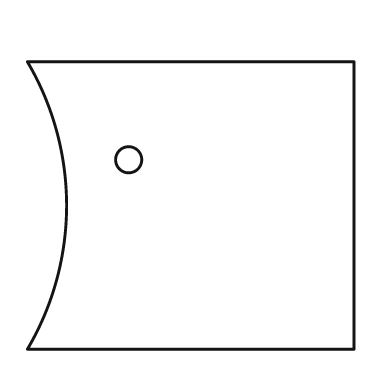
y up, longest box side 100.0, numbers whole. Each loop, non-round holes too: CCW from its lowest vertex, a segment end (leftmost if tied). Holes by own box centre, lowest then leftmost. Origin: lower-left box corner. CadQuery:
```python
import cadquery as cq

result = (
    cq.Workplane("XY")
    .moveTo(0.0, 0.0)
    .lineTo(100.0, 0.0)
    .lineTo(100.0, 88.0)
    .lineTo(0.0, 88.0)
    .threePointArc((12.0, 44.0), (0.0, 0.0))
    .close()
    .moveTo(31.0, 58.0)
    .circle(4.0)
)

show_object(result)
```